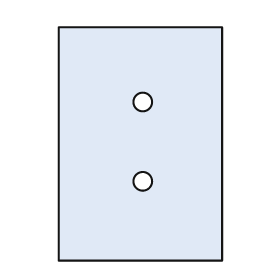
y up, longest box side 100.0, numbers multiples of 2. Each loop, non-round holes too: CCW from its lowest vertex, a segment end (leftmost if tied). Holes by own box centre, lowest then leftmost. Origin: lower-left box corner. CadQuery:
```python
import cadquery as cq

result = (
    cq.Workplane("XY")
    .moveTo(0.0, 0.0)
    .lineTo(70.0, 0.0)
    .lineTo(70.0, 100.0)
    .lineTo(0.0, 100.0)
    .close()
    .moveTo(36.0, 34.0)
    .circle(4.0)
    .moveTo(36.0, 68.0)
    .circle(4.0)
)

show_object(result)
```